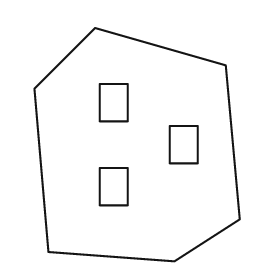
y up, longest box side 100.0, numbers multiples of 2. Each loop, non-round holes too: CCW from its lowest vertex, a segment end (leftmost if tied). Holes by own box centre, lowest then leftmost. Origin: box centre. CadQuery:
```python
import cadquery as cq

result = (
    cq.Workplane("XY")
    .moveTo(16.0, -50.0)
    .lineTo(44.0, -32.0)
    .lineTo(38.0, 34.0)
    .lineTo(-18.0, 50.0)
    .lineTo(-44.0, 24.0)
    .lineTo(-38.0, -46.0)
    .close()
    .moveTo(-16.0, -26.0)
    .lineTo(-4.0, -26.0)
    .lineTo(-4.0, -10.0)
    .lineTo(-16.0, -10.0)
    .close()
    .moveTo(14.0, -8.0)
    .lineTo(26.0, -8.0)
    .lineTo(26.0, 8.0)
    .lineTo(14.0, 8.0)
    .close()
    .moveTo(-16.0, 10.0)
    .lineTo(-4.0, 10.0)
    .lineTo(-4.0, 26.0)
    .lineTo(-16.0, 26.0)
    .close()
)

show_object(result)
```